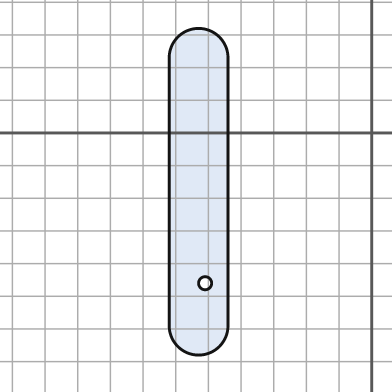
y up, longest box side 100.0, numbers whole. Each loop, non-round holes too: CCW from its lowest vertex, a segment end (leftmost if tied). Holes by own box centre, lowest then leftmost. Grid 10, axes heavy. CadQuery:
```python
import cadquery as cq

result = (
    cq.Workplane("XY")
    .moveTo(-62.0, -59.0)
    .threePointArc((-53.0, -68.0), (-44.0, -59.0))
    .lineTo(-44.0, 23.0)
    .threePointArc((-53.0, 32.0), (-62.0, 23.0))
    .close()
    .moveTo(-51.0, -46.0)
    .circle(2.0)
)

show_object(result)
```